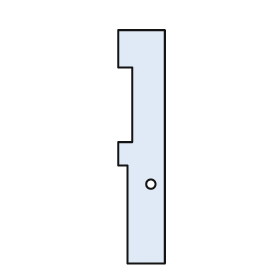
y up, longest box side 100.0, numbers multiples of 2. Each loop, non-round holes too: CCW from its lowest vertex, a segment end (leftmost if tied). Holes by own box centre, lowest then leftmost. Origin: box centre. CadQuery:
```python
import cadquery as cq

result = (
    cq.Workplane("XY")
    .moveTo(-6.0, -50.0)
    .lineTo(10.0, -50.0)
    .lineTo(10.0, 50.0)
    .lineTo(-10.0, 50.0)
    .lineTo(-10.0, 34.0)
    .lineTo(-4.0, 34.0)
    .lineTo(-4.0, 2.0)
    .lineTo(-10.0, 2.0)
    .lineTo(-10.0, -8.0)
    .lineTo(-6.0, -8.0)
    .close()
    .moveTo(4.0, -16.0)
    .circle(2.0)
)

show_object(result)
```